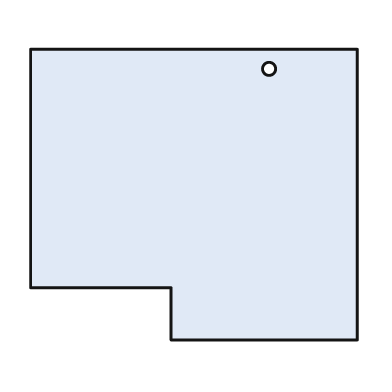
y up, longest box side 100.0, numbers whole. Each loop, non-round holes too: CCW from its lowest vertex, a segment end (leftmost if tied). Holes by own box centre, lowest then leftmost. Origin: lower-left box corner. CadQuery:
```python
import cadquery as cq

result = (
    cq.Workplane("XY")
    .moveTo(43.0, 0.0)
    .lineTo(100.0, 0.0)
    .lineTo(100.0, 89.0)
    .lineTo(0.0, 89.0)
    .lineTo(0.0, 16.0)
    .lineTo(43.0, 16.0)
    .close()
    .moveTo(73.0, 83.0)
    .circle(2.0)
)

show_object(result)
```